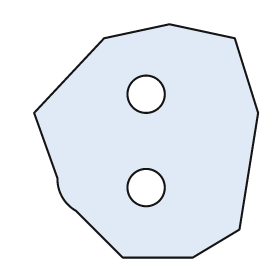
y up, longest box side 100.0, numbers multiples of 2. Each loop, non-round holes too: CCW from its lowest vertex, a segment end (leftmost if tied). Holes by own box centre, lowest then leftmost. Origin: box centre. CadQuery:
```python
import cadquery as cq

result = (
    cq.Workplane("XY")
    .moveTo(-10.0, -50.0)
    .lineTo(20.0, -50.0)
    .lineTo(40.0, -38.0)
    .lineTo(48.0, 12.0)
    .lineTo(38.0, 44.0)
    .lineTo(10.0, 50.0)
    .lineTo(-18.0, 44.0)
    .lineTo(-48.0, 12.0)
    .lineTo(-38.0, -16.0)
    .threePointArc((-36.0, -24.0), (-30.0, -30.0))
    .close()
    .moveTo(0.0, -20.0)
    .circle(8.0)
    .moveTo(0.0, 20.0)
    .circle(8.0)
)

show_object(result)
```